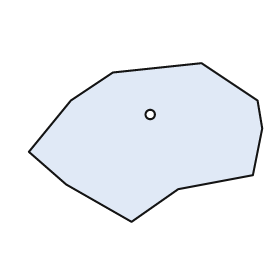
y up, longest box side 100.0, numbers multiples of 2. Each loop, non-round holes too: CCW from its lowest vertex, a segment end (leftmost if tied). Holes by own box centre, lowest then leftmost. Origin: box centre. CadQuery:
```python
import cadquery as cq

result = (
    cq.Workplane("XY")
    .moveTo(-6.0, -34.0)
    .lineTo(14.0, -20.0)
    .lineTo(46.0, -14.0)
    .lineTo(50.0, 6.0)
    .lineTo(48.0, 18.0)
    .lineTo(24.0, 34.0)
    .lineTo(-14.0, 30.0)
    .lineTo(-32.0, 18.0)
    .lineTo(-50.0, -4.0)
    .lineTo(-34.0, -18.0)
    .close()
    .moveTo(2.0, 12.0)
    .circle(2.0)
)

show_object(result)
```